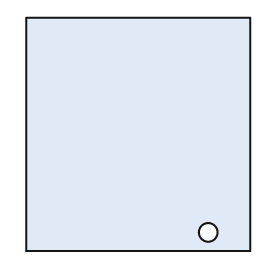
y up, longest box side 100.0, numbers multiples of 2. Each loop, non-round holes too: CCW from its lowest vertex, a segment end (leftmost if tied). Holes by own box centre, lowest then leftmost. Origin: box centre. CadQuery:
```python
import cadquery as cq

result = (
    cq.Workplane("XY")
    .moveTo(-48.0, -50.0)
    .lineTo(48.0, -50.0)
    .lineTo(48.0, 50.0)
    .lineTo(-48.0, 50.0)
    .close()
    .moveTo(30.0, -42.0)
    .circle(4.0)
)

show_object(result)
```